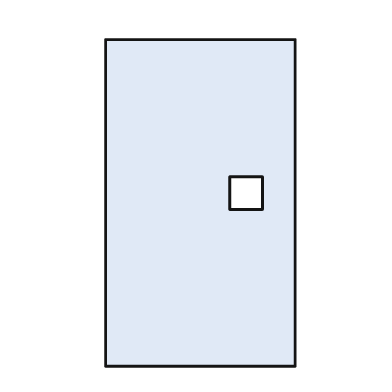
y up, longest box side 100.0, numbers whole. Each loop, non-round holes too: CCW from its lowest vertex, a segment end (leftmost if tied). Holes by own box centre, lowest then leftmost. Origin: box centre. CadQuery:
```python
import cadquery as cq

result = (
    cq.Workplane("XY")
    .moveTo(-29.0, -50.0)
    .lineTo(29.0, -50.0)
    .lineTo(29.0, 50.0)
    .lineTo(-29.0, 50.0)
    .close()
    .moveTo(9.0, -2.0)
    .lineTo(19.0, -2.0)
    .lineTo(19.0, 8.0)
    .lineTo(9.0, 8.0)
    .close()
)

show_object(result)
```